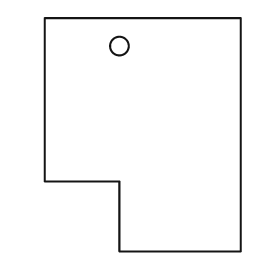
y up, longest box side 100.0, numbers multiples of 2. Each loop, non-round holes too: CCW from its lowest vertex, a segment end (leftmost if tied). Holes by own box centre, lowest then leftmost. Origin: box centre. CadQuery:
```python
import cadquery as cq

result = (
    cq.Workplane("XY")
    .moveTo(-10.0, -50.0)
    .lineTo(42.0, -50.0)
    .lineTo(42.0, 50.0)
    .lineTo(-42.0, 50.0)
    .lineTo(-42.0, -20.0)
    .lineTo(-10.0, -20.0)
    .close()
    .moveTo(-10.0, 38.0)
    .circle(4.0)
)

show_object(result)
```